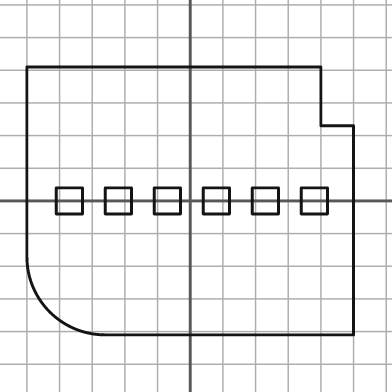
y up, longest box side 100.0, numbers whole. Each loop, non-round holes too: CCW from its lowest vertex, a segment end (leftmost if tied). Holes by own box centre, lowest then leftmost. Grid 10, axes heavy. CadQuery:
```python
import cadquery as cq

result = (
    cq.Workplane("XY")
    .moveTo(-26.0, -41.0)
    .lineTo(50.0, -41.0)
    .lineTo(50.0, 23.0)
    .lineTo(40.0, 23.0)
    .lineTo(40.0, 41.0)
    .lineTo(-50.0, 41.0)
    .lineTo(-50.0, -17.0)
    .threePointArc((-43.0, -34.0), (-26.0, -41.0))
    .close()
    .moveTo(-41.0, -4.0)
    .lineTo(-33.0, -4.0)
    .lineTo(-33.0, 4.0)
    .lineTo(-41.0, 4.0)
    .close()
    .moveTo(-26.0, -4.0)
    .lineTo(-18.0, -4.0)
    .lineTo(-18.0, 4.0)
    .lineTo(-26.0, 4.0)
    .close()
    .moveTo(-11.0, -4.0)
    .lineTo(-3.0, -4.0)
    .lineTo(-3.0, 4.0)
    .lineTo(-11.0, 4.0)
    .close()
    .moveTo(4.0, -4.0)
    .lineTo(12.0, -4.0)
    .lineTo(12.0, 4.0)
    .lineTo(4.0, 4.0)
    .close()
    .moveTo(19.0, -4.0)
    .lineTo(27.0, -4.0)
    .lineTo(27.0, 4.0)
    .lineTo(19.0, 4.0)
    .close()
    .moveTo(34.0, -4.0)
    .lineTo(42.0, -4.0)
    .lineTo(42.0, 4.0)
    .lineTo(34.0, 4.0)
    .close()
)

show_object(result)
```